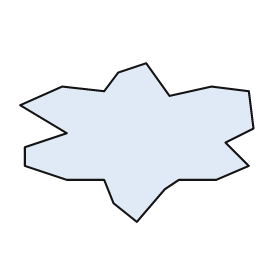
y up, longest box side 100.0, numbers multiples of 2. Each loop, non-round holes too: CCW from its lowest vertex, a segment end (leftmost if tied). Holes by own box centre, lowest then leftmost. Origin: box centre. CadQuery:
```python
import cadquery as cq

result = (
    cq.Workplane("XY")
    .moveTo(0.0, -34.0)
    .lineTo(12.0, -20.0)
    .lineTo(18.0, -16.0)
    .lineTo(34.0, -16.0)
    .lineTo(48.0, -10.0)
    .lineTo(38.0, 0.0)
    .lineTo(50.0, 6.0)
    .lineTo(48.0, 22.0)
    .lineTo(32.0, 24.0)
    .lineTo(14.0, 20.0)
    .lineTo(4.0, 34.0)
    .lineTo(-8.0, 30.0)
    .lineTo(-14.0, 22.0)
    .lineTo(-32.0, 24.0)
    .lineTo(-50.0, 16.0)
    .lineTo(-30.0, 4.0)
    .lineTo(-48.0, -2.0)
    .lineTo(-48.0, -10.0)
    .lineTo(-30.0, -16.0)
    .lineTo(-14.0, -16.0)
    .lineTo(-10.0, -26.0)
    .close()
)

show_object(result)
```